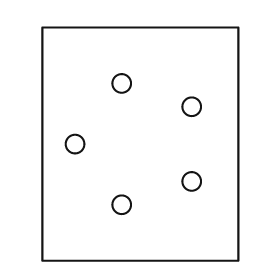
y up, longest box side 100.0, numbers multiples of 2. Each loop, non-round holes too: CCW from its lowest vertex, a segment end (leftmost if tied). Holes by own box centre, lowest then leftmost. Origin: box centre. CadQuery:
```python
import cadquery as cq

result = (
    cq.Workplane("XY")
    .moveTo(-42.0, -50.0)
    .lineTo(42.0, -50.0)
    .lineTo(42.0, 50.0)
    .lineTo(-42.0, 50.0)
    .close()
    .moveTo(-8.0, -26.0)
    .circle(4.0)
    .moveTo(22.0, -16.0)
    .circle(4.0)
    .moveTo(-28.0, 0.0)
    .circle(4.0)
    .moveTo(22.0, 16.0)
    .circle(4.0)
    .moveTo(-8.0, 26.0)
    .circle(4.0)
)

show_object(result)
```